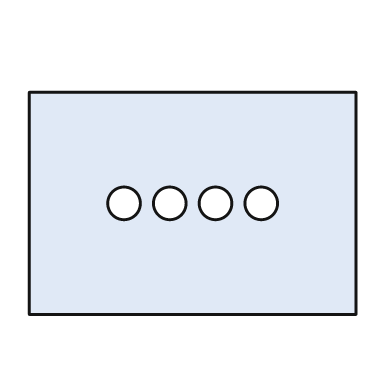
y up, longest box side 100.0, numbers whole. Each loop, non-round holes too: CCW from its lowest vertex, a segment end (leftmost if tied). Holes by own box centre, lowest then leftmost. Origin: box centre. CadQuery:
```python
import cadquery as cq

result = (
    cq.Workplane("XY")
    .moveTo(-50.0, -34.0)
    .lineTo(50.0, -34.0)
    .lineTo(50.0, 34.0)
    .lineTo(-50.0, 34.0)
    .close()
    .moveTo(-21.0, 0.0)
    .circle(5.0)
    .moveTo(-7.0, 0.0)
    .circle(5.0)
    .moveTo(7.0, 0.0)
    .circle(5.0)
    .moveTo(21.0, 0.0)
    .circle(5.0)
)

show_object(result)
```